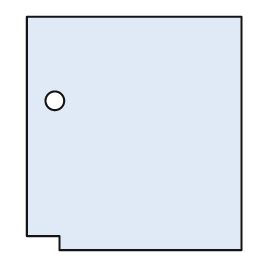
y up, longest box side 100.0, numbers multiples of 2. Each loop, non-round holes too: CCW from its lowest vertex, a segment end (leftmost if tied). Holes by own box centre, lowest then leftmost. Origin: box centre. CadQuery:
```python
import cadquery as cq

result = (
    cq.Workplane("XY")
    .moveTo(-32.0, -50.0)
    .lineTo(46.0, -50.0)
    .lineTo(46.0, 50.0)
    .lineTo(-46.0, 50.0)
    .lineTo(-46.0, -44.0)
    .lineTo(-32.0, -44.0)
    .close()
    .moveTo(-34.0, 14.0)
    .circle(4.0)
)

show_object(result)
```